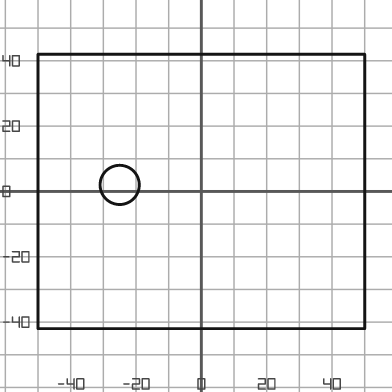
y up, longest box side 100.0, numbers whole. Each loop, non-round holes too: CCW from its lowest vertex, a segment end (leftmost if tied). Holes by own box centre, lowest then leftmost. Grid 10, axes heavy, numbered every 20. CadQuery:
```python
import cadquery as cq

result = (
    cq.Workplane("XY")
    .moveTo(-50.0, -42.0)
    .lineTo(50.0, -42.0)
    .lineTo(50.0, 42.0)
    .lineTo(-50.0, 42.0)
    .close()
    .moveTo(-25.0, 2.0)
    .circle(6.0)
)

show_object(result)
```